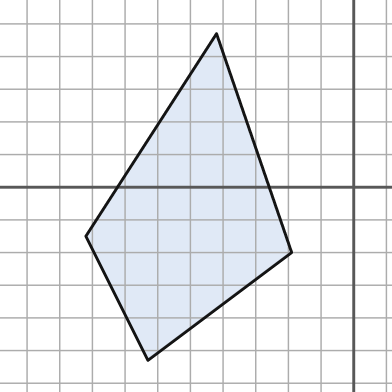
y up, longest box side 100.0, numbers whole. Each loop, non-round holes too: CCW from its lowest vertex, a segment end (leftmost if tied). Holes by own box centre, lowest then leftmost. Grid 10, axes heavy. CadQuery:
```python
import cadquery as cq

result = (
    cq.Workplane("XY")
    .moveTo(-63.0, -53.0)
    .lineTo(-19.0, -20.0)
    .lineTo(-42.0, 47.0)
    .lineTo(-82.0, -15.0)
    .close()
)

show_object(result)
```